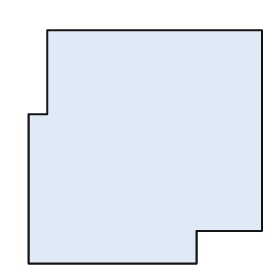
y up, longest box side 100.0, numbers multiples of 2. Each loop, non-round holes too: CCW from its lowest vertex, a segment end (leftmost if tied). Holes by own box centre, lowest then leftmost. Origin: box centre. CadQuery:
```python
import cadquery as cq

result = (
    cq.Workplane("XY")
    .moveTo(-50.0, -50.0)
    .lineTo(22.0, -50.0)
    .lineTo(22.0, -36.0)
    .lineTo(50.0, -36.0)
    .lineTo(50.0, 50.0)
    .lineTo(-42.0, 50.0)
    .lineTo(-42.0, 14.0)
    .lineTo(-50.0, 14.0)
    .close()
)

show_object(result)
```